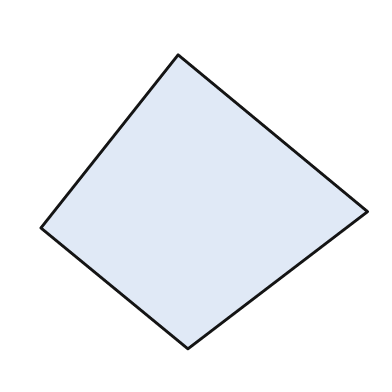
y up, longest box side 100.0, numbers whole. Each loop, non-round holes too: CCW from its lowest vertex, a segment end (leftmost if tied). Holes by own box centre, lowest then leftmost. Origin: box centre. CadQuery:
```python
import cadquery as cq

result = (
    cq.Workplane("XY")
    .moveTo(-5.0, -45.0)
    .lineTo(50.0, -3.0)
    .lineTo(-8.0, 45.0)
    .lineTo(-50.0, -8.0)
    .close()
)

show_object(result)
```